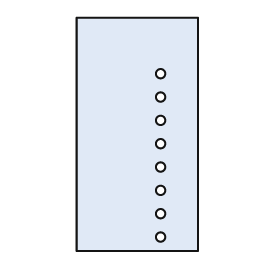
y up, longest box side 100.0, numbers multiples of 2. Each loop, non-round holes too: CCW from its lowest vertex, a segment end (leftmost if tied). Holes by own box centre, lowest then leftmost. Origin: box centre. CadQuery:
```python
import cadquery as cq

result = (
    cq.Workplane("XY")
    .moveTo(-26.0, -50.0)
    .lineTo(26.0, -50.0)
    .lineTo(26.0, 50.0)
    .lineTo(-26.0, 50.0)
    .close()
    .moveTo(10.0, -44.0)
    .circle(2.0)
    .moveTo(10.0, -34.0)
    .circle(2.0)
    .moveTo(10.0, -24.0)
    .circle(2.0)
    .moveTo(10.0, -14.0)
    .circle(2.0)
    .moveTo(10.0, -4.0)
    .circle(2.0)
    .moveTo(10.0, 6.0)
    .circle(2.0)
    .moveTo(10.0, 16.0)
    .circle(2.0)
    .moveTo(10.0, 26.0)
    .circle(2.0)
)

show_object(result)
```